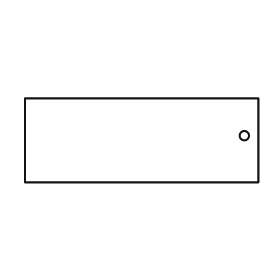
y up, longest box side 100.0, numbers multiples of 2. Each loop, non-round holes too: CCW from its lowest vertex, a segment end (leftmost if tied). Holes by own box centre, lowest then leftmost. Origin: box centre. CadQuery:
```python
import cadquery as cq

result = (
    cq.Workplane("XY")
    .moveTo(-50.0, -18.0)
    .lineTo(50.0, -18.0)
    .lineTo(50.0, 18.0)
    .lineTo(-50.0, 18.0)
    .close()
    .moveTo(44.0, 2.0)
    .circle(2.0)
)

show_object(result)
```